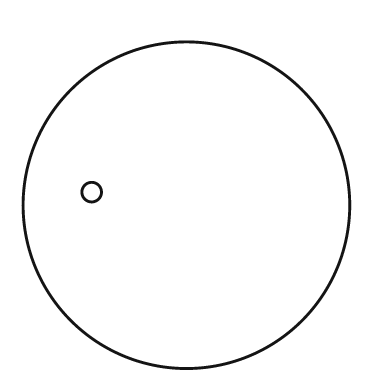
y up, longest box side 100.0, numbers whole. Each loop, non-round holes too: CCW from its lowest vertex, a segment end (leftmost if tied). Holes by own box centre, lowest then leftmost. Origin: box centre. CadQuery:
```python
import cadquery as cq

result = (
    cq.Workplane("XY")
    .moveTo(0.0, 0.0)
    .circle(50.0)
    .moveTo(-29.0, 4.0)
    .circle(3.0)
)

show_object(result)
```